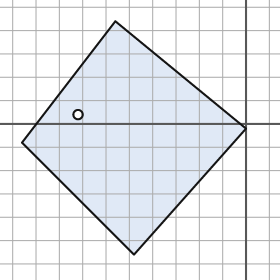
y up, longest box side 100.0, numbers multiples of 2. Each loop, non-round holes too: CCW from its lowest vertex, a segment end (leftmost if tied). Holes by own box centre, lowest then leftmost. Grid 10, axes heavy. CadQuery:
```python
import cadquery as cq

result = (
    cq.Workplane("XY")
    .moveTo(-48.0, -56.0)
    .lineTo(0.0, -2.0)
    .lineTo(-56.0, 44.0)
    .lineTo(-96.0, -8.0)
    .close()
    .moveTo(-72.0, 4.0)
    .circle(2.0)
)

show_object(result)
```